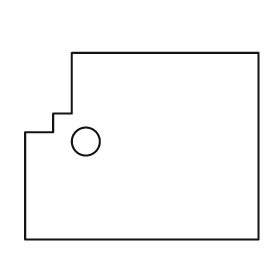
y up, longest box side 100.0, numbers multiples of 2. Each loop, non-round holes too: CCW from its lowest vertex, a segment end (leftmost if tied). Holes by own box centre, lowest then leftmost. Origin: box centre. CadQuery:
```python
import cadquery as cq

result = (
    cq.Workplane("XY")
    .moveTo(-50.0, -40.0)
    .lineTo(50.0, -40.0)
    .lineTo(50.0, 40.0)
    .lineTo(-30.0, 40.0)
    .lineTo(-30.0, 14.0)
    .lineTo(-38.0, 14.0)
    .lineTo(-38.0, 6.0)
    .lineTo(-50.0, 6.0)
    .close()
    .moveTo(-24.0, 2.0)
    .circle(6.0)
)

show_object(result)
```